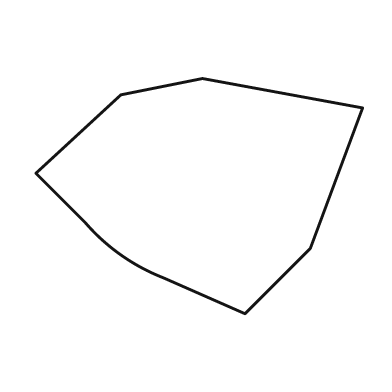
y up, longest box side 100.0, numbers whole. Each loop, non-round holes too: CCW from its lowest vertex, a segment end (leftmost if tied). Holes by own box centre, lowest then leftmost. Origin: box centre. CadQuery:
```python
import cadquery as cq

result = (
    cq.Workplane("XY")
    .moveTo(14.0, -36.0)
    .lineTo(34.0, -16.0)
    .lineTo(50.0, 27.0)
    .lineTo(1.0, 36.0)
    .lineTo(-24.0, 31.0)
    .lineTo(-50.0, 7.0)
    .lineTo(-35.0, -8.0)
    .threePointArc((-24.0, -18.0), (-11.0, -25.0))
    .close()
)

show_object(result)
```